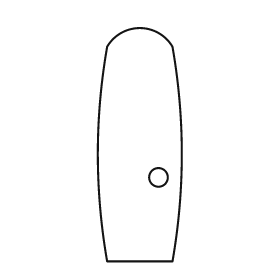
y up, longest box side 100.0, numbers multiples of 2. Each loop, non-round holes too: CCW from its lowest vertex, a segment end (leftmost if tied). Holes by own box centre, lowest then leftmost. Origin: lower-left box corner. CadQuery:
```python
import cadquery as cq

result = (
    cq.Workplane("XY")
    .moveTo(4.0, 0.0)
    .lineTo(32.0, 0.0)
    .threePointArc((36.0, 46.0), (32.0, 92.0))
    .threePointArc((18.0, 100.0), (4.0, 92.0))
    .threePointArc((0.0, 46.0), (4.0, 0.0))
    .close()
    .moveTo(26.0, 36.0)
    .circle(4.0)
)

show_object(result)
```